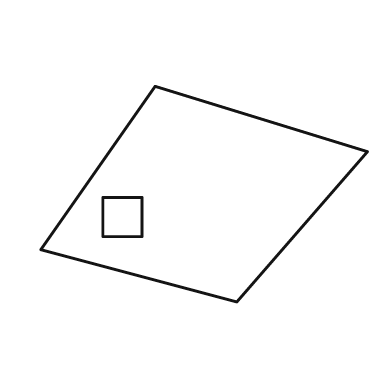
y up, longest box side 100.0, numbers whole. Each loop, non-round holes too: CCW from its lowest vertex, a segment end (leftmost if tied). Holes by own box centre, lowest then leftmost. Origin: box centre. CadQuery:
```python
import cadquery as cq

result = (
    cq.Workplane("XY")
    .moveTo(10.0, -33.0)
    .lineTo(50.0, 13.0)
    .lineTo(-15.0, 33.0)
    .lineTo(-50.0, -17.0)
    .close()
    .moveTo(-31.0, -13.0)
    .lineTo(-19.0, -13.0)
    .lineTo(-19.0, -1.0)
    .lineTo(-31.0, -1.0)
    .close()
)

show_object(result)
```